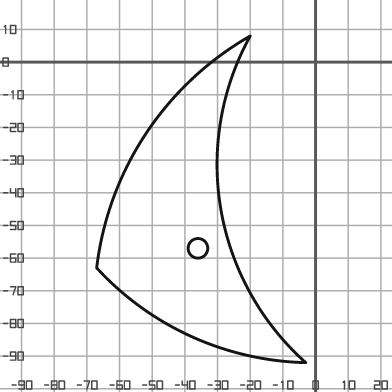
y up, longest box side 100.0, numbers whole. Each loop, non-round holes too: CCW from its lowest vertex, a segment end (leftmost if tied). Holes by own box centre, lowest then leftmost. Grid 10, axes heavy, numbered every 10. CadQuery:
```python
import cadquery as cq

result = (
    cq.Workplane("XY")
    .moveTo(-3.0, -92.0)
    .threePointArc((-29.0, -45.0), (-20.0, 8.0))
    .threePointArc((-52.0, -22.0), (-67.0, -63.0))
    .threePointArc((-38.0, -84.0), (-3.0, -92.0))
    .close()
    .moveTo(-36.0, -57.0)
    .circle(3.0)
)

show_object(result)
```